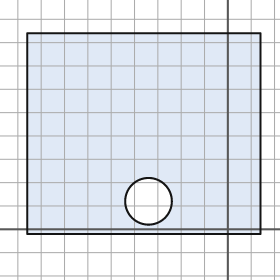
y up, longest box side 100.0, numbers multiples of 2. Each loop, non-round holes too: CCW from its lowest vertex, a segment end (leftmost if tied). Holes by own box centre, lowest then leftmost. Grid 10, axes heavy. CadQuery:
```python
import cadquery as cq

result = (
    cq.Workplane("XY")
    .moveTo(-86.0, -2.0)
    .lineTo(14.0, -2.0)
    .lineTo(14.0, 84.0)
    .lineTo(-86.0, 84.0)
    .close()
    .moveTo(-34.0, 12.0)
    .circle(10.0)
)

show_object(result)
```